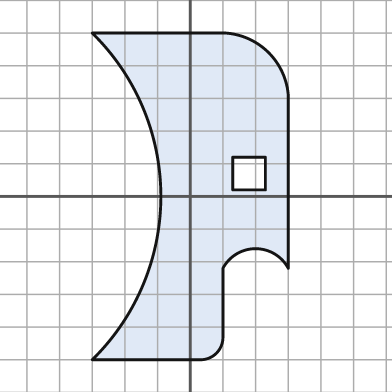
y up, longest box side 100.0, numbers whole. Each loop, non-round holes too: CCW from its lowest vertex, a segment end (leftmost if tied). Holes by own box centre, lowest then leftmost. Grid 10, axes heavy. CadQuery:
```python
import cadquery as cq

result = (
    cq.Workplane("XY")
    .moveTo(-30.0, -50.0)
    .lineTo(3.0, -50.0)
    .threePointArc((8.0, -48.0), (10.0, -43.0))
    .lineTo(10.0, -22.0)
    .threePointArc((20.0, -16.0), (30.0, -22.0))
    .lineTo(30.0, 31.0)
    .threePointArc((24.0, 44.0), (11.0, 50.0))
    .lineTo(-30.0, 50.0)
    .threePointArc((-9.0, 0.0), (-30.0, -50.0))
    .close()
    .moveTo(13.0, 2.0)
    .lineTo(23.0, 2.0)
    .lineTo(23.0, 12.0)
    .lineTo(13.0, 12.0)
    .close()
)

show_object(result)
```